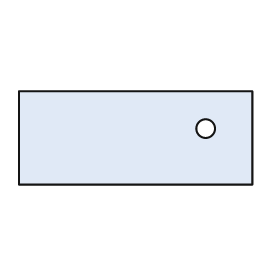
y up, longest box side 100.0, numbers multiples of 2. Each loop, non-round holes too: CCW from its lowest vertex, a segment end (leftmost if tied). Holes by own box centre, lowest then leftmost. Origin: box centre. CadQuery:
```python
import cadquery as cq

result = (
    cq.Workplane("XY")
    .moveTo(-50.0, -20.0)
    .lineTo(50.0, -20.0)
    .lineTo(50.0, 20.0)
    .lineTo(-50.0, 20.0)
    .close()
    .moveTo(30.0, 4.0)
    .circle(4.0)
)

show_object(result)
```